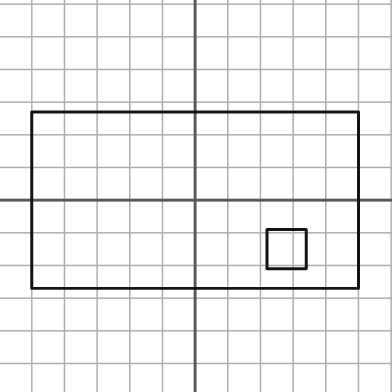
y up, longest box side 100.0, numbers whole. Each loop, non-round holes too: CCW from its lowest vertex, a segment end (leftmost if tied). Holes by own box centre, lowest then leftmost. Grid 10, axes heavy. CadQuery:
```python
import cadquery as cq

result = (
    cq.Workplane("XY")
    .moveTo(-50.0, -27.0)
    .lineTo(50.0, -27.0)
    .lineTo(50.0, 27.0)
    .lineTo(-50.0, 27.0)
    .close()
    .moveTo(22.0, -21.0)
    .lineTo(34.0, -21.0)
    .lineTo(34.0, -9.0)
    .lineTo(22.0, -9.0)
    .close()
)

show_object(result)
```